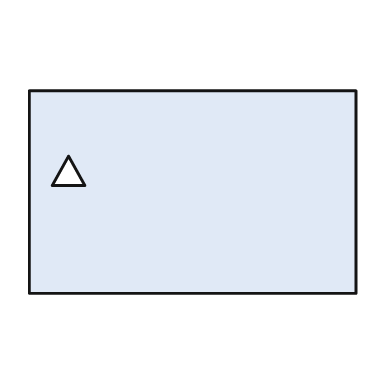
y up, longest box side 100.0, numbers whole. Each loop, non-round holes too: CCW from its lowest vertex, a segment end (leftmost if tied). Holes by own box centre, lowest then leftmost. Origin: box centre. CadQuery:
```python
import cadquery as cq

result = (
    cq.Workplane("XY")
    .moveTo(-50.0, -31.0)
    .lineTo(50.0, -31.0)
    .lineTo(50.0, 31.0)
    .lineTo(-50.0, 31.0)
    .close()
    .moveTo(-43.0, 2.0)
    .lineTo(-33.0, 2.0)
    .lineTo(-38.0, 11.0)
    .close()
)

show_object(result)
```